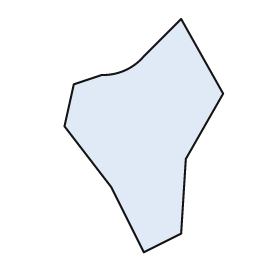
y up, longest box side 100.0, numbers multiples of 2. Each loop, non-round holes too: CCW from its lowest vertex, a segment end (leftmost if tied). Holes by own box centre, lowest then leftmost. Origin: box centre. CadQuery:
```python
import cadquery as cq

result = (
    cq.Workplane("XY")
    .moveTo(0.0, -50.0)
    .lineTo(16.0, -42.0)
    .lineTo(18.0, -10.0)
    .lineTo(34.0, 18.0)
    .lineTo(16.0, 50.0)
    .lineTo(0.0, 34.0)
    .threePointArc((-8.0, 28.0), (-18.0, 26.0))
    .lineTo(-30.0, 22.0)
    .lineTo(-34.0, 4.0)
    .lineTo(-14.0, -22.0)
    .close()
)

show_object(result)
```